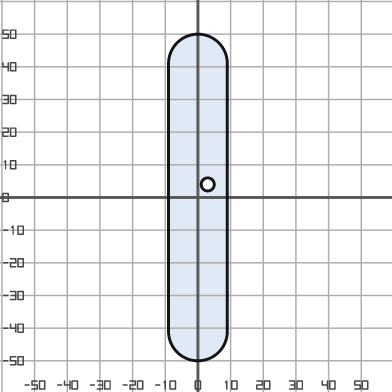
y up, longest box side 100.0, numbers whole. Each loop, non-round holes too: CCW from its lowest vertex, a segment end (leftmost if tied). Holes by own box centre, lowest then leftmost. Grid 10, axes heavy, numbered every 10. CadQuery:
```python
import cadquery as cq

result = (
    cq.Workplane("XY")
    .moveTo(-9.0, -41.0)
    .threePointArc((0.0, -50.0), (9.0, -41.0))
    .lineTo(9.0, 41.0)
    .threePointArc((0.0, 50.0), (-9.0, 41.0))
    .close()
    .moveTo(3.0, 4.0)
    .circle(2.0)
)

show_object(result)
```